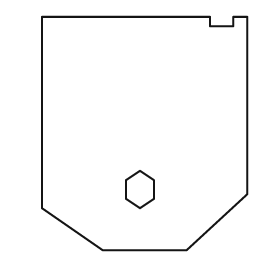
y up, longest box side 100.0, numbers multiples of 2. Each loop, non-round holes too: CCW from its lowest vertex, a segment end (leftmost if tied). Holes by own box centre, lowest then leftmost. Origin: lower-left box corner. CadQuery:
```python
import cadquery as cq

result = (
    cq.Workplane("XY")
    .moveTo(26.0, 0.0)
    .lineTo(62.0, 0.0)
    .lineTo(88.0, 24.0)
    .lineTo(88.0, 100.0)
    .lineTo(82.0, 100.0)
    .lineTo(82.0, 96.0)
    .lineTo(72.0, 96.0)
    .lineTo(72.0, 100.0)
    .lineTo(0.0, 100.0)
    .lineTo(0.0, 18.0)
    .close()
    .moveTo(42.0, 18.0)
    .lineTo(48.0, 22.0)
    .lineTo(48.0, 30.0)
    .lineTo(42.0, 34.0)
    .lineTo(36.0, 30.0)
    .lineTo(36.0, 22.0)
    .close()
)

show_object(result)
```